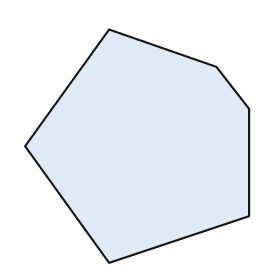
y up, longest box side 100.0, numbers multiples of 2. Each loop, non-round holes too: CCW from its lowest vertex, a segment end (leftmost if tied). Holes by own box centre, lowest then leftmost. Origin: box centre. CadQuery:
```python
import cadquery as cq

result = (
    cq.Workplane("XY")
    .moveTo(-12.0, -50.0)
    .lineTo(48.0, -30.0)
    .lineTo(48.0, 16.0)
    .lineTo(34.0, 34.0)
    .lineTo(-12.0, 50.0)
    .lineTo(-48.0, 0.0)
    .close()
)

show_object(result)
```